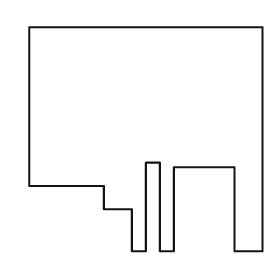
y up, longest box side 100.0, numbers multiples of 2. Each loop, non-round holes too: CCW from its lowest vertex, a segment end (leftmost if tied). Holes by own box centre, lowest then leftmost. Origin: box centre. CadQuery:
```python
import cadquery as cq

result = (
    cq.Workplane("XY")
    .moveTo(-6.0, -48.0)
    .lineTo(0.0, -48.0)
    .lineTo(0.0, -10.0)
    .lineTo(6.0, -10.0)
    .lineTo(6.0, -48.0)
    .lineTo(12.0, -48.0)
    .lineTo(12.0, -12.0)
    .lineTo(38.0, -12.0)
    .lineTo(38.0, -48.0)
    .lineTo(50.0, -48.0)
    .lineTo(50.0, 48.0)
    .lineTo(-50.0, 48.0)
    .lineTo(-50.0, -20.0)
    .lineTo(-18.0, -20.0)
    .lineTo(-18.0, -30.0)
    .lineTo(-6.0, -30.0)
    .close()
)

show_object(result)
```